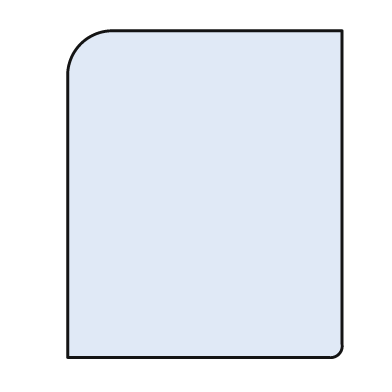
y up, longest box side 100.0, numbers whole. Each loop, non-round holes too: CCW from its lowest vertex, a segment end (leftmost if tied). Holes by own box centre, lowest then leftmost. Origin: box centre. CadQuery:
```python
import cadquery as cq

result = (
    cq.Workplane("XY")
    .moveTo(-42.0, -50.0)
    .lineTo(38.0, -50.0)
    .threePointArc((41.0, -49.0), (42.0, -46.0))
    .lineTo(42.0, 50.0)
    .lineTo(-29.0, 50.0)
    .threePointArc((-38.0, 46.0), (-42.0, 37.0))
    .close()
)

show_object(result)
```